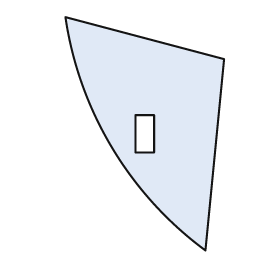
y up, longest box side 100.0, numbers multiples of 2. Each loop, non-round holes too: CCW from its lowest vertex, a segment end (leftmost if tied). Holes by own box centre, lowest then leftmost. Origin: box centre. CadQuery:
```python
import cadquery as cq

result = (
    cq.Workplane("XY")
    .moveTo(26.0, -50.0)
    .lineTo(34.0, 32.0)
    .lineTo(-34.0, 50.0)
    .threePointArc((-14.0, -6.0), (26.0, -50.0))
    .close()
    .moveTo(-4.0, -8.0)
    .lineTo(4.0, -8.0)
    .lineTo(4.0, 8.0)
    .lineTo(-4.0, 8.0)
    .close()
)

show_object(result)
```